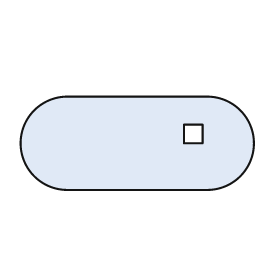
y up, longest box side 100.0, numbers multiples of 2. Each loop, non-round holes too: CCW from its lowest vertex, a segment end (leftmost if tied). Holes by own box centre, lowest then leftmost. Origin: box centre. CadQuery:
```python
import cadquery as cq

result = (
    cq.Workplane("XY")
    .moveTo(-30.0, -20.0)
    .lineTo(30.0, -20.0)
    .threePointArc((50.0, 0.0), (30.0, 20.0))
    .lineTo(-30.0, 20.0)
    .threePointArc((-50.0, 0.0), (-30.0, -20.0))
    .close()
    .moveTo(20.0, 0.0)
    .lineTo(28.0, 0.0)
    .lineTo(28.0, 8.0)
    .lineTo(20.0, 8.0)
    .close()
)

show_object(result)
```